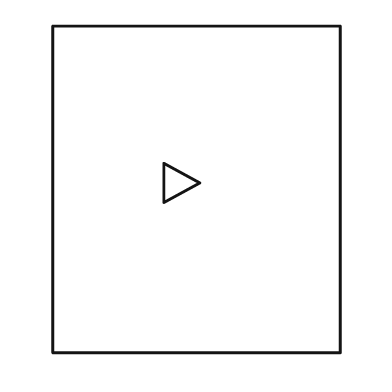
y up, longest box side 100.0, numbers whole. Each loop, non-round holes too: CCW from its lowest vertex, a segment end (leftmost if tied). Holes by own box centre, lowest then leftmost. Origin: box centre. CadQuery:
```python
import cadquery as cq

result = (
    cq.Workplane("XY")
    .moveTo(-44.0, -50.0)
    .lineTo(44.0, -50.0)
    .lineTo(44.0, 50.0)
    .lineTo(-44.0, 50.0)
    .close()
    .moveTo(-10.0, -4.0)
    .lineTo(1.0, 2.0)
    .lineTo(-10.0, 8.0)
    .close()
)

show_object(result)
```